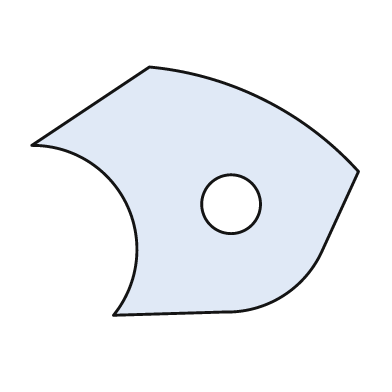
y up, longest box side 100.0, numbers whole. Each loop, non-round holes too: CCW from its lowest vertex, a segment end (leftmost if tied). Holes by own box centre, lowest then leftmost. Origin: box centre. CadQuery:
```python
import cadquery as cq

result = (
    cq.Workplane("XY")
    .moveTo(-25.0, -38.0)
    .lineTo(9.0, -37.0)
    .threePointArc((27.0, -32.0), (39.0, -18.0))
    .lineTo(50.0, 6.0)
    .threePointArc((21.0, 28.0), (-14.0, 38.0))
    .lineTo(-50.0, 14.0)
    .threePointArc((-21.0, -4.0), (-25.0, -38.0))
    .close()
    .moveTo(11.0, -4.0)
    .circle(9.0)
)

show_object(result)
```